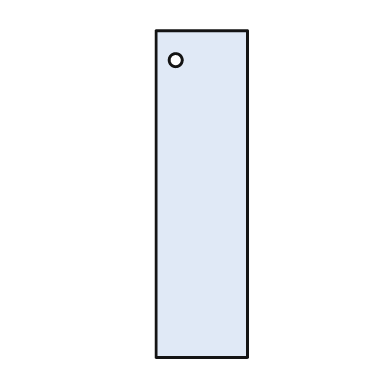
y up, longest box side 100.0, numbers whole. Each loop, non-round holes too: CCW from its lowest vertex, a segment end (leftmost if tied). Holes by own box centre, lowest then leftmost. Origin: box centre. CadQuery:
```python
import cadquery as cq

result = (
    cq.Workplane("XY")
    .moveTo(-14.0, -50.0)
    .lineTo(14.0, -50.0)
    .lineTo(14.0, 50.0)
    .lineTo(-14.0, 50.0)
    .close()
    .moveTo(-8.0, 41.0)
    .circle(2.0)
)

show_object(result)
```